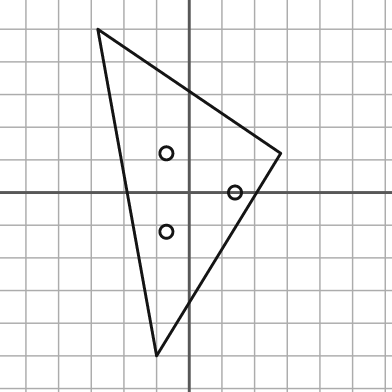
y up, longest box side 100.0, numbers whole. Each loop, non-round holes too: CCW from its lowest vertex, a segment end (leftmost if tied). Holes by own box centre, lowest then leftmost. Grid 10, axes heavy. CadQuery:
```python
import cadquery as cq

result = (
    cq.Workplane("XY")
    .moveTo(-10.0, -50.0)
    .lineTo(28.0, 12.0)
    .lineTo(-28.0, 50.0)
    .close()
    .moveTo(-7.0, -12.0)
    .circle(2.0)
    .moveTo(14.0, 0.0)
    .circle(2.0)
    .moveTo(-7.0, 12.0)
    .circle(2.0)
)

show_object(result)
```